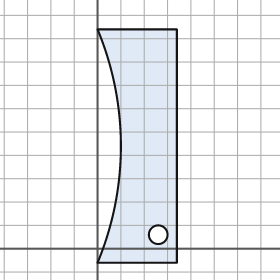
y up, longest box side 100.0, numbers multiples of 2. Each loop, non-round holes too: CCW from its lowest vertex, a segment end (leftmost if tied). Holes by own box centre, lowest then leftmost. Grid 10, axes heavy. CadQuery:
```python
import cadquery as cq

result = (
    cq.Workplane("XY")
    .moveTo(0.0, -6.0)
    .lineTo(34.0, -6.0)
    .lineTo(34.0, 94.0)
    .lineTo(0.0, 94.0)
    .threePointArc((10.0, 44.0), (0.0, -6.0))
    .close()
    .moveTo(26.0, 6.0)
    .circle(4.0)
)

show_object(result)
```